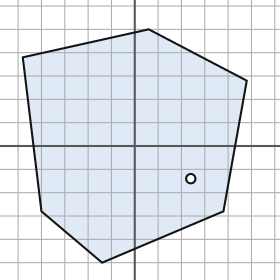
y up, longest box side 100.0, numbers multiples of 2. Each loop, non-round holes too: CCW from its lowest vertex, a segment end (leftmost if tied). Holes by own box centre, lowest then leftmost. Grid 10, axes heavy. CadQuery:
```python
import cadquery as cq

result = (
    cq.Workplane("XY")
    .moveTo(-14.0, -50.0)
    .lineTo(38.0, -28.0)
    .lineTo(48.0, 28.0)
    .lineTo(6.0, 50.0)
    .lineTo(-48.0, 38.0)
    .lineTo(-40.0, -28.0)
    .close()
    .moveTo(24.0, -14.0)
    .circle(2.0)
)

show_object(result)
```